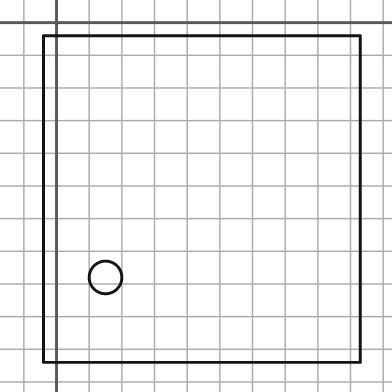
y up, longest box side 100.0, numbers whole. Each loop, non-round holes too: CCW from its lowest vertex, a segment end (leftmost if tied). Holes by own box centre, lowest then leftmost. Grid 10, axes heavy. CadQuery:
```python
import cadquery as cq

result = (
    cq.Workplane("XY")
    .moveTo(-4.0, -104.0)
    .lineTo(93.0, -104.0)
    .lineTo(93.0, -4.0)
    .lineTo(-4.0, -4.0)
    .close()
    .moveTo(15.0, -78.0)
    .circle(5.0)
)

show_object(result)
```